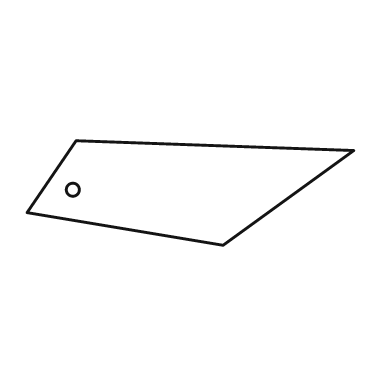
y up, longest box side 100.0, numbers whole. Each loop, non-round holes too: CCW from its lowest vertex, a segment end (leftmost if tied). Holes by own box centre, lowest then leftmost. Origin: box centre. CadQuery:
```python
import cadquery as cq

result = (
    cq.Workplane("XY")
    .moveTo(10.0, -16.0)
    .lineTo(50.0, 13.0)
    .lineTo(-35.0, 16.0)
    .lineTo(-50.0, -6.0)
    .close()
    .moveTo(-36.0, 1.0)
    .circle(2.0)
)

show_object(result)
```